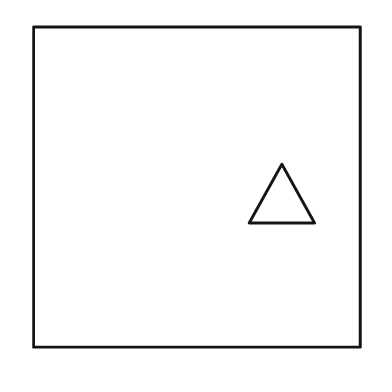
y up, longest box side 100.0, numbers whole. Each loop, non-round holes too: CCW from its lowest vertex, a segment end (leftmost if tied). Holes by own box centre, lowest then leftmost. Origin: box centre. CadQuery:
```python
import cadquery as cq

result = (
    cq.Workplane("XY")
    .moveTo(-50.0, -49.0)
    .lineTo(50.0, -49.0)
    .lineTo(50.0, 49.0)
    .lineTo(-50.0, 49.0)
    .close()
    .moveTo(16.0, -11.0)
    .lineTo(36.0, -11.0)
    .lineTo(26.0, 7.0)
    .close()
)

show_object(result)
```